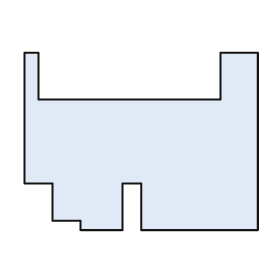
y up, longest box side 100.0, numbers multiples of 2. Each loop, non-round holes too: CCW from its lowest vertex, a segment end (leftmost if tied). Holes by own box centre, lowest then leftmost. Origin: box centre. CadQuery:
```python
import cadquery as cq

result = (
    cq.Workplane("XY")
    .moveTo(-26.0, -38.0)
    .lineTo(-8.0, -38.0)
    .lineTo(-8.0, -18.0)
    .lineTo(0.0, -18.0)
    .lineTo(0.0, -38.0)
    .lineTo(50.0, -38.0)
    .lineTo(50.0, 38.0)
    .lineTo(34.0, 38.0)
    .lineTo(34.0, 18.0)
    .lineTo(-44.0, 18.0)
    .lineTo(-44.0, 38.0)
    .lineTo(-50.0, 38.0)
    .lineTo(-50.0, -18.0)
    .lineTo(-38.0, -18.0)
    .lineTo(-38.0, -34.0)
    .lineTo(-26.0, -34.0)
    .close()
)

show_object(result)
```